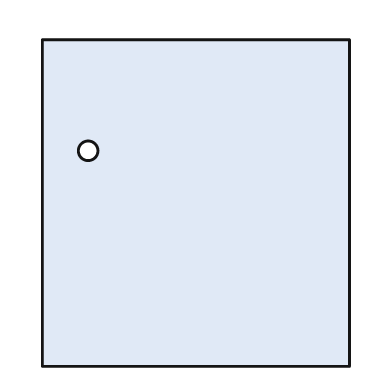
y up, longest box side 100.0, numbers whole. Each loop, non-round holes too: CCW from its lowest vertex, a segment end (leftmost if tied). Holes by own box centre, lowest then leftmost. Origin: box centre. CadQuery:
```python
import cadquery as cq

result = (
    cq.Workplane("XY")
    .moveTo(-47.0, -50.0)
    .lineTo(47.0, -50.0)
    .lineTo(47.0, 50.0)
    .lineTo(-47.0, 50.0)
    .close()
    .moveTo(-33.0, 16.0)
    .circle(3.0)
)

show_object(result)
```